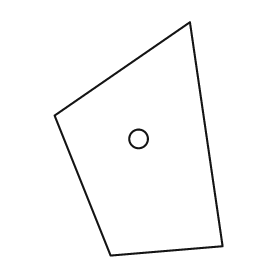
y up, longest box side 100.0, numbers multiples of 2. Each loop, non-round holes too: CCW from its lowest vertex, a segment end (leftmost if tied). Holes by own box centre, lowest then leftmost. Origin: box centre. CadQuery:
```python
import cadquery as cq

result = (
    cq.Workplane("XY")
    .moveTo(-12.0, -50.0)
    .lineTo(36.0, -46.0)
    .lineTo(22.0, 50.0)
    .lineTo(-36.0, 10.0)
    .close()
    .moveTo(0.0, 0.0)
    .circle(4.0)
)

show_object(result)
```